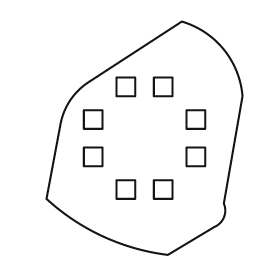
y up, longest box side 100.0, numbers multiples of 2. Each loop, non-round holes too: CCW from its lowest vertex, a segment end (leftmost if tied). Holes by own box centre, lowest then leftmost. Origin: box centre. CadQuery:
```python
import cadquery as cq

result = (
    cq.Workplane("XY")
    .moveTo(10.0, -50.0)
    .lineTo(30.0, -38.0)
    .threePointArc((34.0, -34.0), (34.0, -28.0))
    .lineTo(42.0, 18.0)
    .threePointArc((34.0, 38.0), (16.0, 50.0))
    .lineTo(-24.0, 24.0)
    .threePointArc((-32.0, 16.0), (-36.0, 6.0))
    .lineTo(-42.0, -26.0)
    .threePointArc((-18.0, -42.0), (10.0, -50.0))
    .close()
    .moveTo(-12.0, -26.0)
    .lineTo(-4.0, -26.0)
    .lineTo(-4.0, -18.0)
    .lineTo(-12.0, -18.0)
    .close()
    .moveTo(4.0, -26.0)
    .lineTo(12.0, -26.0)
    .lineTo(12.0, -18.0)
    .lineTo(4.0, -18.0)
    .close()
    .moveTo(-26.0, -12.0)
    .lineTo(-18.0, -12.0)
    .lineTo(-18.0, -4.0)
    .lineTo(-26.0, -4.0)
    .close()
    .moveTo(18.0, -12.0)
    .lineTo(26.0, -12.0)
    .lineTo(26.0, -4.0)
    .lineTo(18.0, -4.0)
    .close()
    .moveTo(-26.0, 4.0)
    .lineTo(-18.0, 4.0)
    .lineTo(-18.0, 12.0)
    .lineTo(-26.0, 12.0)
    .close()
    .moveTo(18.0, 4.0)
    .lineTo(26.0, 4.0)
    .lineTo(26.0, 12.0)
    .lineTo(18.0, 12.0)
    .close()
    .moveTo(-12.0, 18.0)
    .lineTo(-4.0, 18.0)
    .lineTo(-4.0, 26.0)
    .lineTo(-12.0, 26.0)
    .close()
    .moveTo(4.0, 18.0)
    .lineTo(12.0, 18.0)
    .lineTo(12.0, 26.0)
    .lineTo(4.0, 26.0)
    .close()
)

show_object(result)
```